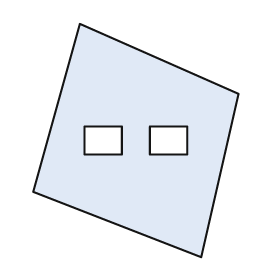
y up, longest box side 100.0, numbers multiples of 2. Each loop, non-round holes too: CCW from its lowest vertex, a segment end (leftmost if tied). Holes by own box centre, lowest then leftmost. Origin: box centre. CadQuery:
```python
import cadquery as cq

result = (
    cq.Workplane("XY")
    .moveTo(28.0, -50.0)
    .lineTo(44.0, 20.0)
    .lineTo(-24.0, 50.0)
    .lineTo(-44.0, -22.0)
    .close()
    .moveTo(-22.0, -6.0)
    .lineTo(-6.0, -6.0)
    .lineTo(-6.0, 6.0)
    .lineTo(-22.0, 6.0)
    .close()
    .moveTo(6.0, -6.0)
    .lineTo(22.0, -6.0)
    .lineTo(22.0, 6.0)
    .lineTo(6.0, 6.0)
    .close()
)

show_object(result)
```